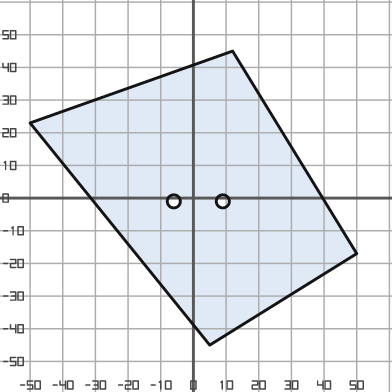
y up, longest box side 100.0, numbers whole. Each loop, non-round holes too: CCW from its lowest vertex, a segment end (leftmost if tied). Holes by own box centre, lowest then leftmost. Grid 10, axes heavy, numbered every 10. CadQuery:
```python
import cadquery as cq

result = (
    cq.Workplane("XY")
    .moveTo(5.0, -45.0)
    .lineTo(50.0, -17.0)
    .lineTo(12.0, 45.0)
    .lineTo(-50.0, 23.0)
    .close()
    .moveTo(-6.0, -1.0)
    .circle(2.0)
    .moveTo(9.0, -1.0)
    .circle(2.0)
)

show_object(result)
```